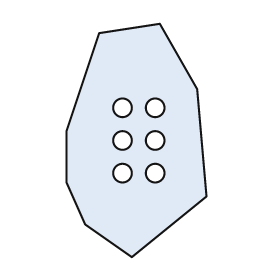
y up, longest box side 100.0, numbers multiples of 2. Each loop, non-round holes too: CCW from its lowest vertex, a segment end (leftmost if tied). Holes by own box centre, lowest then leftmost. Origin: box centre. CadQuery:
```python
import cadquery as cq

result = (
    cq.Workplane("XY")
    .moveTo(-2.0, -50.0)
    .lineTo(30.0, -24.0)
    .lineTo(26.0, 22.0)
    .lineTo(10.0, 50.0)
    .lineTo(-16.0, 46.0)
    .lineTo(-30.0, 4.0)
    .lineTo(-30.0, -18.0)
    .lineTo(-22.0, -36.0)
    .close()
    .moveTo(-6.0, -14.0)
    .circle(4.0)
    .moveTo(8.0, -14.0)
    .circle(4.0)
    .moveTo(-6.0, 0.0)
    .circle(4.0)
    .moveTo(8.0, 0.0)
    .circle(4.0)
    .moveTo(-6.0, 14.0)
    .circle(4.0)
    .moveTo(8.0, 14.0)
    .circle(4.0)
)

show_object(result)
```